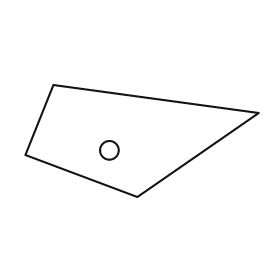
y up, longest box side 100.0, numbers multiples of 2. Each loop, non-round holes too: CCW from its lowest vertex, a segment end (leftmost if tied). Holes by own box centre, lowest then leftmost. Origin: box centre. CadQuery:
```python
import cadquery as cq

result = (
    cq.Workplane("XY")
    .moveTo(-2.0, -24.0)
    .lineTo(50.0, 12.0)
    .lineTo(-38.0, 24.0)
    .lineTo(-50.0, -6.0)
    .close()
    .moveTo(-14.0, -4.0)
    .circle(4.0)
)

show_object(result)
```